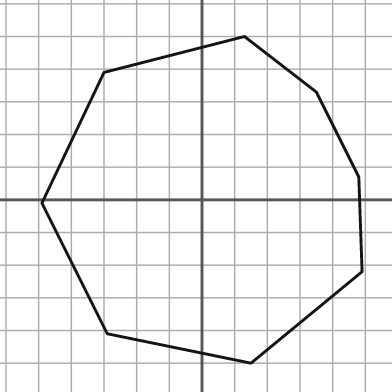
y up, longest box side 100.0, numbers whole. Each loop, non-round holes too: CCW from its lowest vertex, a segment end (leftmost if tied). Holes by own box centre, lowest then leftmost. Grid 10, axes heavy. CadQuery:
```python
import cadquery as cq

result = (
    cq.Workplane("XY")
    .moveTo(15.0, -50.0)
    .lineTo(49.0, -22.0)
    .lineTo(48.0, 7.0)
    .lineTo(35.0, 33.0)
    .lineTo(13.0, 50.0)
    .lineTo(-30.0, 39.0)
    .lineTo(-49.0, -1.0)
    .lineTo(-29.0, -41.0)
    .close()
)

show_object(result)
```